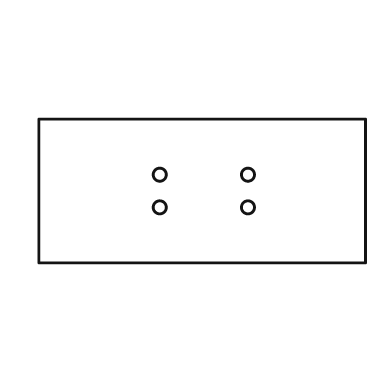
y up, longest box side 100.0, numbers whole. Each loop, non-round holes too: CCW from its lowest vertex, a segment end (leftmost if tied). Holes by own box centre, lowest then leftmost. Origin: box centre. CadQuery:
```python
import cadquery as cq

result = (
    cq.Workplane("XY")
    .moveTo(-50.0, -22.0)
    .lineTo(50.0, -22.0)
    .lineTo(50.0, 22.0)
    .lineTo(-50.0, 22.0)
    .close()
    .moveTo(-13.0, -5.0)
    .circle(2.0)
    .moveTo(14.0, -5.0)
    .circle(2.0)
    .moveTo(-13.0, 5.0)
    .circle(2.0)
    .moveTo(14.0, 5.0)
    .circle(2.0)
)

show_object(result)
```